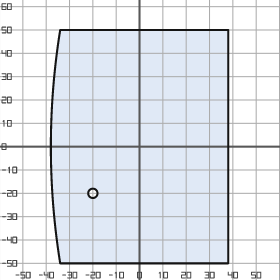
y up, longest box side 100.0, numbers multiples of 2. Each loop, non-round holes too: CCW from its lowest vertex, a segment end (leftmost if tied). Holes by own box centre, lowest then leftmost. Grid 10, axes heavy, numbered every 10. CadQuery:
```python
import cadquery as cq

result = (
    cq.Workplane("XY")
    .moveTo(-34.0, -50.0)
    .lineTo(38.0, -50.0)
    .lineTo(38.0, 50.0)
    .lineTo(-34.0, 50.0)
    .threePointArc((-38.0, 0.0), (-34.0, -50.0))
    .close()
    .moveTo(-20.0, -20.0)
    .circle(2.0)
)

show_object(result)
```